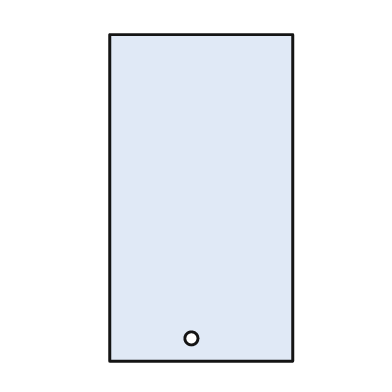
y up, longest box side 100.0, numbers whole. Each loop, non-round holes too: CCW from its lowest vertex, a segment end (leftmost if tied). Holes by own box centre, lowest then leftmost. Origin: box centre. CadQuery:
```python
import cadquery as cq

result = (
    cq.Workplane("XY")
    .moveTo(-28.0, -50.0)
    .lineTo(28.0, -50.0)
    .lineTo(28.0, 50.0)
    .lineTo(-28.0, 50.0)
    .close()
    .moveTo(-3.0, -43.0)
    .circle(2.0)
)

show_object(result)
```